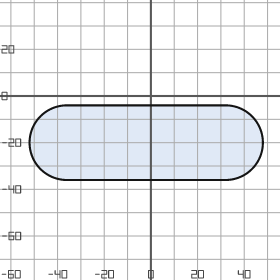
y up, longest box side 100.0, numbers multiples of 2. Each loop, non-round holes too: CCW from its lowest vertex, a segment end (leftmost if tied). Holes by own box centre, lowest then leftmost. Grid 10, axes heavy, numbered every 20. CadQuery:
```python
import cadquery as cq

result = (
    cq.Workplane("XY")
    .moveTo(-36.0, -36.0)
    .lineTo(32.0, -36.0)
    .threePointArc((48.0, -20.0), (32.0, -4.0))
    .lineTo(-36.0, -4.0)
    .threePointArc((-52.0, -20.0), (-36.0, -36.0))
    .close()
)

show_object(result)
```